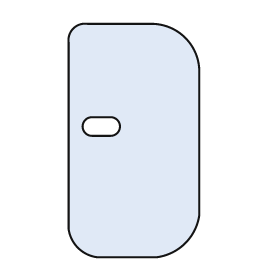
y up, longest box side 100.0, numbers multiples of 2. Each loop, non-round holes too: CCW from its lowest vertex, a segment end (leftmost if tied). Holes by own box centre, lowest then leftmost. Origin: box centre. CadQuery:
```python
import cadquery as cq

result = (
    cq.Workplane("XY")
    .moveTo(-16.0, -50.0)
    .lineTo(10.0, -50.0)
    .threePointArc((22.0, -44.0), (28.0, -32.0))
    .lineTo(28.0, 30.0)
    .threePointArc((22.0, 44.0), (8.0, 50.0))
    .lineTo(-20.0, 50.0)
    .threePointArc((-26.0, 48.0), (-28.0, 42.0))
    .lineTo(-28.0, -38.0)
    .threePointArc((-24.0, -46.0), (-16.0, -50.0))
    .close()
    .moveTo(-18.0, 2.0)
    .lineTo(-10.0, 2.0)
    .threePointArc((-6.0, 6.0), (-10.0, 10.0))
    .lineTo(-18.0, 10.0)
    .threePointArc((-22.0, 6.0), (-18.0, 2.0))
    .close()
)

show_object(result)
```